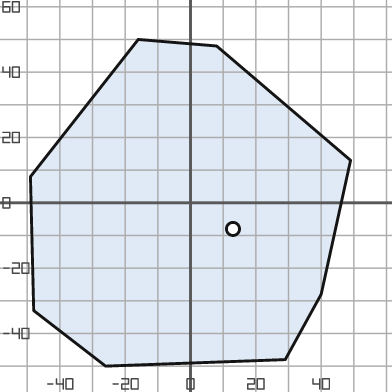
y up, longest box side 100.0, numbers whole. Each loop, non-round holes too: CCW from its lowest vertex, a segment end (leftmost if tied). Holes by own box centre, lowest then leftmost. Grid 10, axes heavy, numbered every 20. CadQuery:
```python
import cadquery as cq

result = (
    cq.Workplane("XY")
    .moveTo(-26.0, -50.0)
    .lineTo(29.0, -48.0)
    .lineTo(40.0, -28.0)
    .lineTo(49.0, 13.0)
    .lineTo(8.0, 48.0)
    .lineTo(-16.0, 50.0)
    .lineTo(-49.0, 8.0)
    .lineTo(-48.0, -33.0)
    .close()
    .moveTo(13.0, -8.0)
    .circle(2.0)
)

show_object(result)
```